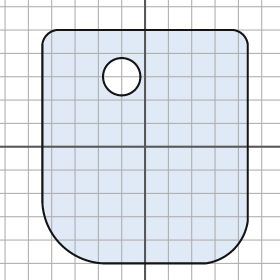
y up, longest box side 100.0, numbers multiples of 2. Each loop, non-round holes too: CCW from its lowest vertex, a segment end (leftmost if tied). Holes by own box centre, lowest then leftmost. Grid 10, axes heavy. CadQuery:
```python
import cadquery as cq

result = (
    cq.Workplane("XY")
    .moveTo(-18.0, -50.0)
    .lineTo(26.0, -50.0)
    .threePointArc((38.0, -44.0), (44.0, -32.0))
    .lineTo(44.0, 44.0)
    .threePointArc((42.0, 48.0), (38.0, 50.0))
    .lineTo(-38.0, 50.0)
    .threePointArc((-42.0, 48.0), (-44.0, 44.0))
    .lineTo(-44.0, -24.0)
    .threePointArc((-36.0, -42.0), (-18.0, -50.0))
    .close()
    .moveTo(-10.0, 30.0)
    .circle(8.0)
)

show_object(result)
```